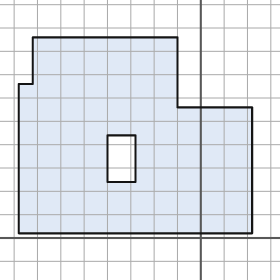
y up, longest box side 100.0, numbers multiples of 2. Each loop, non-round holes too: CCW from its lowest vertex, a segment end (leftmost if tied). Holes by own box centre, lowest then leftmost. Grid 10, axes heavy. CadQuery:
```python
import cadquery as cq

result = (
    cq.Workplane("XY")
    .moveTo(-78.0, 2.0)
    .lineTo(22.0, 2.0)
    .lineTo(22.0, 56.0)
    .lineTo(-10.0, 56.0)
    .lineTo(-10.0, 86.0)
    .lineTo(-72.0, 86.0)
    .lineTo(-72.0, 66.0)
    .lineTo(-78.0, 66.0)
    .close()
    .moveTo(-40.0, 24.0)
    .lineTo(-28.0, 24.0)
    .lineTo(-28.0, 44.0)
    .lineTo(-40.0, 44.0)
    .close()
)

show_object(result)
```